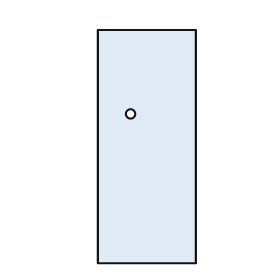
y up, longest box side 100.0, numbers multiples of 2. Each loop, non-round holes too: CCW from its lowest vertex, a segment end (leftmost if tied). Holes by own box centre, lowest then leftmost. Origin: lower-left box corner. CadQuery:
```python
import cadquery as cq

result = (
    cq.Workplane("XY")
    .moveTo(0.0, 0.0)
    .lineTo(42.0, 0.0)
    .lineTo(42.0, 100.0)
    .lineTo(0.0, 100.0)
    .close()
    .moveTo(14.0, 64.0)
    .circle(2.0)
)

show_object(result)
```